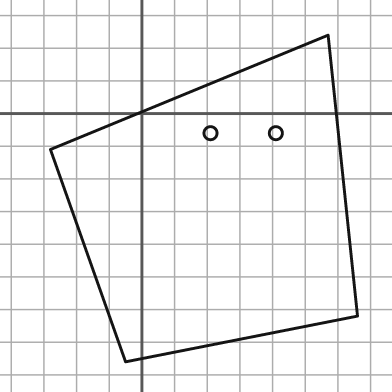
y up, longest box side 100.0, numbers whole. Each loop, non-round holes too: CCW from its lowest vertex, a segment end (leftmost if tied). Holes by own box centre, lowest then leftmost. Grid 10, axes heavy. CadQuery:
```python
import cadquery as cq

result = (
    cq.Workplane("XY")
    .moveTo(-5.0, -76.0)
    .lineTo(66.0, -62.0)
    .lineTo(57.0, 24.0)
    .lineTo(-28.0, -11.0)
    .close()
    .moveTo(21.0, -6.0)
    .circle(2.0)
    .moveTo(41.0, -6.0)
    .circle(2.0)
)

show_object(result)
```